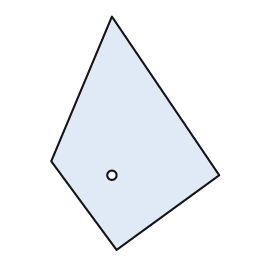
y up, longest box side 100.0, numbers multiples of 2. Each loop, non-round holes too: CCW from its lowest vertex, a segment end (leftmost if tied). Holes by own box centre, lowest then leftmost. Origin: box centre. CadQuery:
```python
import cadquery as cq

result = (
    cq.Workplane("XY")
    .moveTo(-8.0, -50.0)
    .lineTo(36.0, -18.0)
    .lineTo(-10.0, 50.0)
    .lineTo(-36.0, -12.0)
    .close()
    .moveTo(-10.0, -18.0)
    .circle(2.0)
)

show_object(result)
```